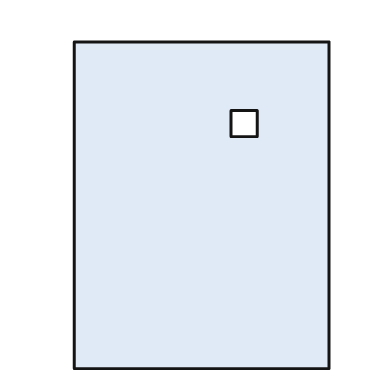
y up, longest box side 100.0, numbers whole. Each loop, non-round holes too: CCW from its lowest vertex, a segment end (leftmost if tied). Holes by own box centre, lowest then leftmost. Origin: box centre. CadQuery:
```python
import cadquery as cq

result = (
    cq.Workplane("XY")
    .moveTo(-39.0, -50.0)
    .lineTo(39.0, -50.0)
    .lineTo(39.0, 50.0)
    .lineTo(-39.0, 50.0)
    .close()
    .moveTo(9.0, 21.0)
    .lineTo(17.0, 21.0)
    .lineTo(17.0, 29.0)
    .lineTo(9.0, 29.0)
    .close()
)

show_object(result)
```